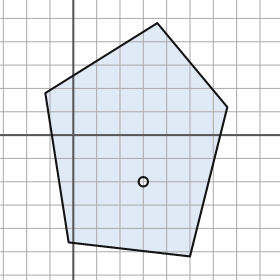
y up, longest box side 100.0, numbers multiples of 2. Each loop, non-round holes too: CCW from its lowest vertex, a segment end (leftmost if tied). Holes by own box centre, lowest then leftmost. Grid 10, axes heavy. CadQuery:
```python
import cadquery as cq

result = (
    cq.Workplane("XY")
    .moveTo(50.0, -52.0)
    .lineTo(66.0, 12.0)
    .lineTo(36.0, 48.0)
    .lineTo(-12.0, 18.0)
    .lineTo(-2.0, -46.0)
    .close()
    .moveTo(30.0, -20.0)
    .circle(2.0)
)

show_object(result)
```